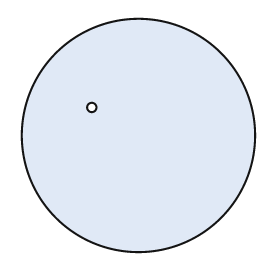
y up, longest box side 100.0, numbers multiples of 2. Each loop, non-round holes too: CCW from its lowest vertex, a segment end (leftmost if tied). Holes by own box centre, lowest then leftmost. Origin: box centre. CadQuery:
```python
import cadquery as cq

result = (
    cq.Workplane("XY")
    .moveTo(0.0, 0.0)
    .circle(50.0)
    .moveTo(-20.0, 12.0)
    .circle(2.0)
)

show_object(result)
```